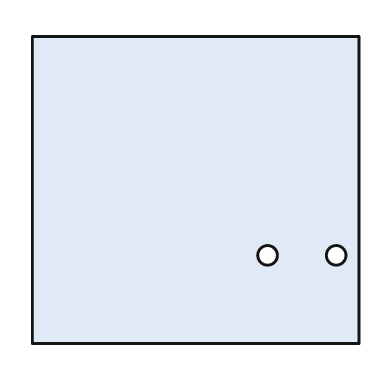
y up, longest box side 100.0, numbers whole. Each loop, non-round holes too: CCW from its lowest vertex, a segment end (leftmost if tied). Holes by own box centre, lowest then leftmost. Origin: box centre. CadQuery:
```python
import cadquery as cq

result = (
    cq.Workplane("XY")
    .moveTo(-50.0, -47.0)
    .lineTo(50.0, -47.0)
    .lineTo(50.0, 47.0)
    .lineTo(-50.0, 47.0)
    .close()
    .moveTo(22.0, -20.0)
    .circle(3.0)
    .moveTo(43.0, -20.0)
    .circle(3.0)
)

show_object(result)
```